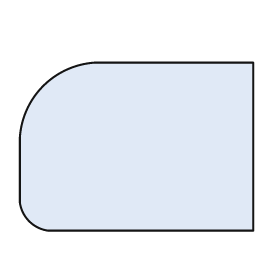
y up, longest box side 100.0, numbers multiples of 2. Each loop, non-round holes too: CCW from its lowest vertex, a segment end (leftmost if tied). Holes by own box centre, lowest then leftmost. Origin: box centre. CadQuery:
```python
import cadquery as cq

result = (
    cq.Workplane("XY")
    .moveTo(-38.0, -36.0)
    .lineTo(50.0, -36.0)
    .lineTo(50.0, 36.0)
    .lineTo(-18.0, 36.0)
    .threePointArc((-40.0, 26.0), (-50.0, 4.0))
    .lineTo(-50.0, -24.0)
    .threePointArc((-46.0, -32.0), (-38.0, -36.0))
    .close()
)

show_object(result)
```